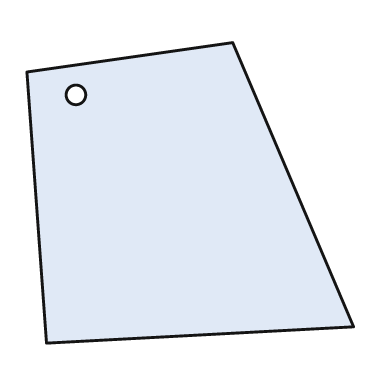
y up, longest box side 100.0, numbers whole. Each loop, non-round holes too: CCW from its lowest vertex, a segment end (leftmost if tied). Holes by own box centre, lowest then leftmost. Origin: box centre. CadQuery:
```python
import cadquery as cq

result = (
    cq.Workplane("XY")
    .moveTo(-44.0, -46.0)
    .lineTo(50.0, -41.0)
    .lineTo(13.0, 46.0)
    .lineTo(-50.0, 37.0)
    .close()
    .moveTo(-35.0, 30.0)
    .circle(3.0)
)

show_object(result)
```